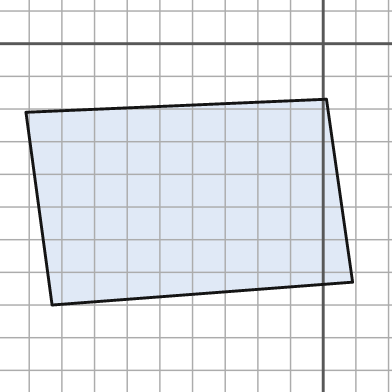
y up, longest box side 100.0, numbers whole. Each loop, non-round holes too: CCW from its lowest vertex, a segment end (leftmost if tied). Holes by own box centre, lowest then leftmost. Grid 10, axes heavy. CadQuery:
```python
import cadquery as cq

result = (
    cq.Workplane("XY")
    .moveTo(-83.0, -80.0)
    .lineTo(9.0, -73.0)
    .lineTo(1.0, -17.0)
    .lineTo(-91.0, -21.0)
    .close()
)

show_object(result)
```